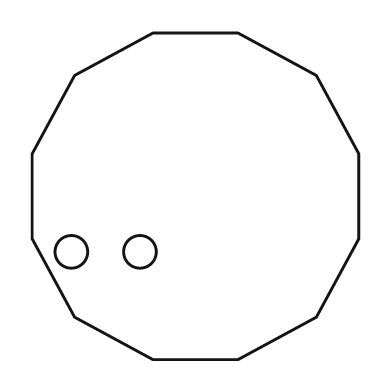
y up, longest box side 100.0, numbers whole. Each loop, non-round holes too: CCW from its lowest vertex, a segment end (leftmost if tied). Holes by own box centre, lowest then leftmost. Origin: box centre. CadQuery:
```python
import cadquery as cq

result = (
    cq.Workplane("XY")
    .moveTo(-13.0, -50.0)
    .lineTo(13.0, -50.0)
    .lineTo(37.0, -37.0)
    .lineTo(50.0, -13.0)
    .lineTo(50.0, 13.0)
    .lineTo(37.0, 37.0)
    .lineTo(13.0, 50.0)
    .lineTo(-13.0, 50.0)
    .lineTo(-37.0, 37.0)
    .lineTo(-50.0, 13.0)
    .lineTo(-50.0, -13.0)
    .lineTo(-37.0, -37.0)
    .close()
    .moveTo(-38.0, -17.0)
    .circle(5.0)
    .moveTo(-17.0, -17.0)
    .circle(5.0)
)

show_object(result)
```